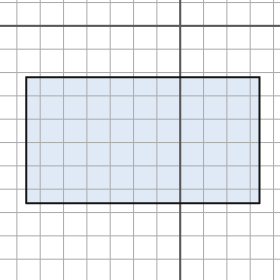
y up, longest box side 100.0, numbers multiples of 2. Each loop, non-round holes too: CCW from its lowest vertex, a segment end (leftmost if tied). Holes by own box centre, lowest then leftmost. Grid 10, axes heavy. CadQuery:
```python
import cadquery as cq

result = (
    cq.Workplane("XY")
    .moveTo(-66.0, -76.0)
    .lineTo(34.0, -76.0)
    .lineTo(34.0, -22.0)
    .lineTo(-66.0, -22.0)
    .close()
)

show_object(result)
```